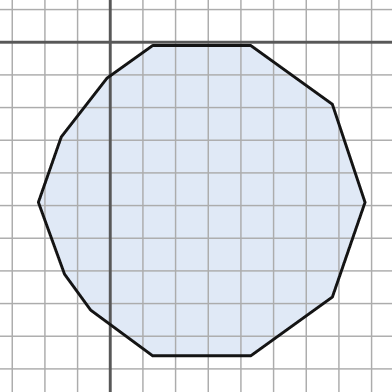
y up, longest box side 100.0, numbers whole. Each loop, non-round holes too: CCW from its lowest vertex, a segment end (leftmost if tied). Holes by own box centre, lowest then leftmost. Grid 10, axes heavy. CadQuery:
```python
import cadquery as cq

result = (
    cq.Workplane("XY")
    .moveTo(13.0, -96.0)
    .lineTo(43.0, -96.0)
    .lineTo(68.0, -78.0)
    .lineTo(78.0, -49.0)
    .lineTo(68.0, -19.0)
    .lineTo(43.0, -1.0)
    .lineTo(13.0, -1.0)
    .lineTo(-1.0, -11.0)
    .lineTo(-15.0, -29.0)
    .lineTo(-22.0, -49.0)
    .lineTo(-14.0, -71.0)
    .lineTo(-6.0, -82.0)
    .close()
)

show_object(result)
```